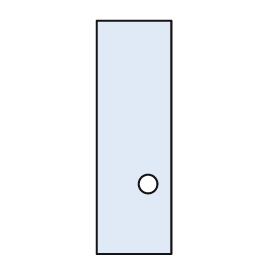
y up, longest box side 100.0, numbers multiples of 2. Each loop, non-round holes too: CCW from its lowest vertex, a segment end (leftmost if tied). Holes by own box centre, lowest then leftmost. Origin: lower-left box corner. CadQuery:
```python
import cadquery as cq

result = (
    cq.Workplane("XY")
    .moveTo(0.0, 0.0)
    .lineTo(32.0, 0.0)
    .lineTo(32.0, 100.0)
    .lineTo(0.0, 100.0)
    .close()
    .moveTo(22.0, 30.0)
    .circle(4.0)
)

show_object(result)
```